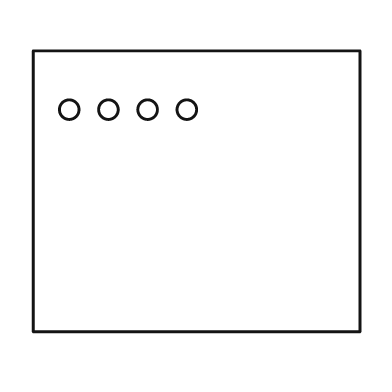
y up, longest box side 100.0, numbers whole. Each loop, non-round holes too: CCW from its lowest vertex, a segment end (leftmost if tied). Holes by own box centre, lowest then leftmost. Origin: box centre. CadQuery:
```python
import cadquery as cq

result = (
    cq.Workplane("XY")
    .moveTo(-50.0, -43.0)
    .lineTo(50.0, -43.0)
    .lineTo(50.0, 43.0)
    .lineTo(-50.0, 43.0)
    .close()
    .moveTo(-39.0, 25.0)
    .circle(3.0)
    .moveTo(-27.0, 25.0)
    .circle(3.0)
    .moveTo(-15.0, 25.0)
    .circle(3.0)
    .moveTo(-3.0, 25.0)
    .circle(3.0)
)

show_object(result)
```